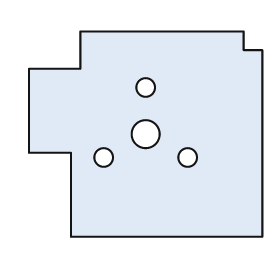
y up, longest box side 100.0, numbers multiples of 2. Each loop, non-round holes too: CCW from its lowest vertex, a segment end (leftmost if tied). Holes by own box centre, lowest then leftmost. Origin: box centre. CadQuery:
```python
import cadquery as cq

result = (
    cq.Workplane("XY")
    .moveTo(-32.0, -44.0)
    .lineTo(50.0, -44.0)
    .lineTo(50.0, 36.0)
    .lineTo(42.0, 36.0)
    .lineTo(42.0, 44.0)
    .lineTo(-28.0, 44.0)
    .lineTo(-28.0, 28.0)
    .lineTo(-50.0, 28.0)
    .lineTo(-50.0, -8.0)
    .lineTo(-32.0, -8.0)
    .close()
    .moveTo(-18.0, -10.0)
    .circle(4.0)
    .moveTo(18.0, -10.0)
    .circle(4.0)
    .moveTo(0.0, 0.0)
    .circle(6.0)
    .moveTo(0.0, 20.0)
    .circle(4.0)
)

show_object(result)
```